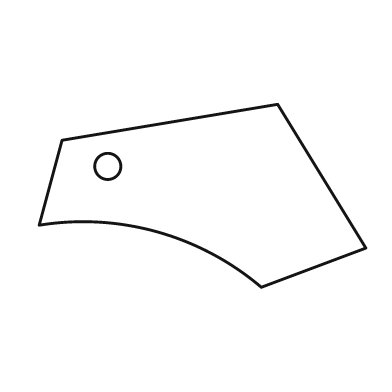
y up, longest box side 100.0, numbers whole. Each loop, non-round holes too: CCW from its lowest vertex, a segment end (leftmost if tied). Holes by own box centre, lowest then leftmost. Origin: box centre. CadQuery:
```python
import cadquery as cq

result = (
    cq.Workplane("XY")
    .moveTo(18.0, -28.0)
    .lineTo(50.0, -16.0)
    .lineTo(23.0, 28.0)
    .lineTo(-43.0, 17.0)
    .lineTo(-50.0, -9.0)
    .threePointArc((-14.0, -11.0), (18.0, -28.0))
    .close()
    .moveTo(-29.0, 9.0)
    .circle(4.0)
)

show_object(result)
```